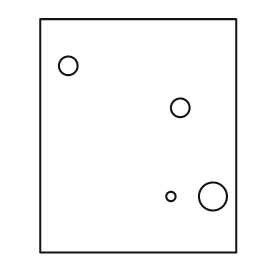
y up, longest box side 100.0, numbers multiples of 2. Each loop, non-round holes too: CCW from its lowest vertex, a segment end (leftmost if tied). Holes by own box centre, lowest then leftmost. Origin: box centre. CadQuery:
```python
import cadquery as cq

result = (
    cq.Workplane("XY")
    .moveTo(-42.0, -50.0)
    .lineTo(42.0, -50.0)
    .lineTo(42.0, 50.0)
    .lineTo(-42.0, 50.0)
    .close()
    .moveTo(14.0, -26.0)
    .circle(2.0)
    .moveTo(32.0, -26.0)
    .circle(6.0)
    .moveTo(18.0, 12.0)
    .circle(4.0)
    .moveTo(-30.0, 30.0)
    .circle(4.0)
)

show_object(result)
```